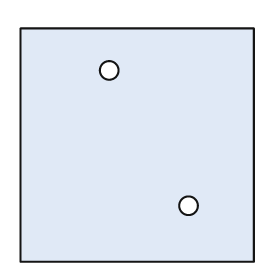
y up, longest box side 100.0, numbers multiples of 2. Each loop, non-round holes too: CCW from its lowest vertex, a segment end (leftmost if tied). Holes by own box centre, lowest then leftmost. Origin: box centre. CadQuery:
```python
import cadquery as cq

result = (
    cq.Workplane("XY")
    .moveTo(-50.0, -50.0)
    .lineTo(50.0, -50.0)
    .lineTo(50.0, 50.0)
    .lineTo(-50.0, 50.0)
    .close()
    .moveTo(22.0, -26.0)
    .circle(4.0)
    .moveTo(-12.0, 32.0)
    .circle(4.0)
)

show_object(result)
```